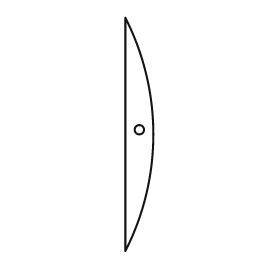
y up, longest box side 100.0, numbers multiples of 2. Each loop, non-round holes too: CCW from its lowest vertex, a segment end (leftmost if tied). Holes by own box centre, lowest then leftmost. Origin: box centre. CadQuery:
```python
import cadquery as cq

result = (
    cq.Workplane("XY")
    .moveTo(-6.0, -50.0)
    .threePointArc((6.0, 0.0), (-6.0, 50.0))
    .close()
    .moveTo(0.0, 2.0)
    .circle(2.0)
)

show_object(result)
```